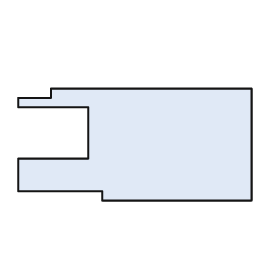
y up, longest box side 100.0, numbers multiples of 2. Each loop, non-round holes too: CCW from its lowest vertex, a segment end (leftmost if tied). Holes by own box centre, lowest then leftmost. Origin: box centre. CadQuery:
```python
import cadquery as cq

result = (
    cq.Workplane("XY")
    .moveTo(-14.0, -24.0)
    .lineTo(50.0, -24.0)
    .lineTo(50.0, 24.0)
    .lineTo(-36.0, 24.0)
    .lineTo(-36.0, 20.0)
    .lineTo(-50.0, 20.0)
    .lineTo(-50.0, 16.0)
    .lineTo(-20.0, 16.0)
    .lineTo(-20.0, -6.0)
    .lineTo(-50.0, -6.0)
    .lineTo(-50.0, -20.0)
    .lineTo(-14.0, -20.0)
    .close()
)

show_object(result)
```